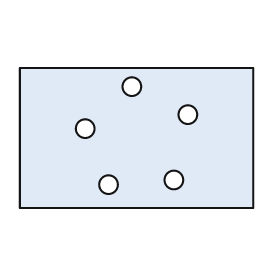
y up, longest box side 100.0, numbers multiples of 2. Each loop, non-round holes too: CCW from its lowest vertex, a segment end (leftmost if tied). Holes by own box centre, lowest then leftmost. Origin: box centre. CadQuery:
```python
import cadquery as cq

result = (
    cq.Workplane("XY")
    .moveTo(-50.0, -30.0)
    .lineTo(50.0, -30.0)
    .lineTo(50.0, 30.0)
    .lineTo(-50.0, 30.0)
    .close()
    .moveTo(-12.0, -20.0)
    .circle(4.0)
    .moveTo(16.0, -18.0)
    .circle(4.0)
    .moveTo(-22.0, 4.0)
    .circle(4.0)
    .moveTo(22.0, 10.0)
    .circle(4.0)
    .moveTo(-2.0, 22.0)
    .circle(4.0)
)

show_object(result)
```